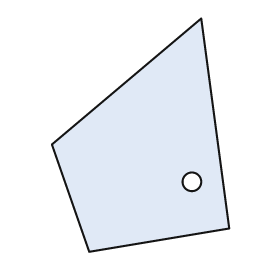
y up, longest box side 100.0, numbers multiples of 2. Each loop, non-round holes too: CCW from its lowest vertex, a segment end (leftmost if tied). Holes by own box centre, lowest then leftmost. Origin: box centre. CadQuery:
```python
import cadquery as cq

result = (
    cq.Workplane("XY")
    .moveTo(-22.0, -50.0)
    .lineTo(38.0, -40.0)
    .lineTo(26.0, 50.0)
    .lineTo(-38.0, -4.0)
    .close()
    .moveTo(22.0, -20.0)
    .circle(4.0)
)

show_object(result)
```